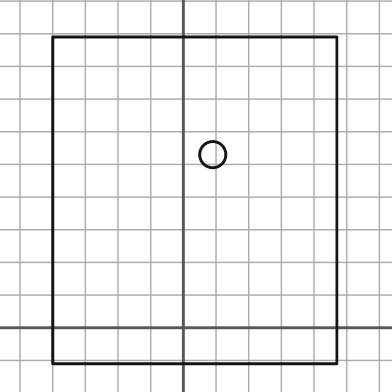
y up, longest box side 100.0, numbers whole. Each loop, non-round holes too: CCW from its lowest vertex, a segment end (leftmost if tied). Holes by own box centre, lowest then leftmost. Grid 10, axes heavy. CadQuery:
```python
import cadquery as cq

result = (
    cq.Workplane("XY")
    .moveTo(-40.0, -11.0)
    .lineTo(47.0, -11.0)
    .lineTo(47.0, 89.0)
    .lineTo(-40.0, 89.0)
    .close()
    .moveTo(9.0, 53.0)
    .circle(4.0)
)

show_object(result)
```